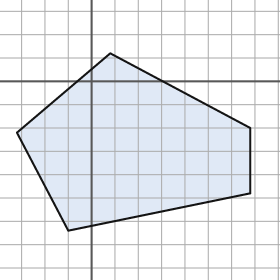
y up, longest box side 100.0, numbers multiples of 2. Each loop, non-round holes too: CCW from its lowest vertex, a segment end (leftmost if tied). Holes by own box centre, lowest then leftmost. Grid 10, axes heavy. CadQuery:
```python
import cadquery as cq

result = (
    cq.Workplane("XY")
    .moveTo(-10.0, -64.0)
    .lineTo(68.0, -48.0)
    .lineTo(68.0, -20.0)
    .lineTo(8.0, 12.0)
    .lineTo(-32.0, -22.0)
    .close()
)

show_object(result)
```